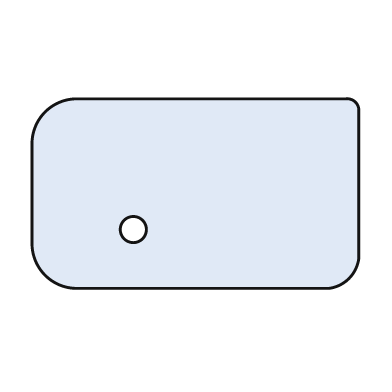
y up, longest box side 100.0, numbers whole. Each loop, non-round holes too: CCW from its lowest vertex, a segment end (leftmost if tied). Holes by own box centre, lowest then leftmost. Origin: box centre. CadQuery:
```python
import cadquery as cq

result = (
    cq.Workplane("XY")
    .moveTo(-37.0, -29.0)
    .lineTo(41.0, -29.0)
    .threePointArc((47.0, -26.0), (50.0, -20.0))
    .lineTo(50.0, 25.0)
    .threePointArc((49.0, 28.0), (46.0, 29.0))
    .lineTo(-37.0, 29.0)
    .threePointArc((-46.0, 25.0), (-50.0, 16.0))
    .lineTo(-50.0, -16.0)
    .threePointArc((-46.0, -25.0), (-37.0, -29.0))
    .close()
    .moveTo(-19.0, -11.0)
    .circle(4.0)
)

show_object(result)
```